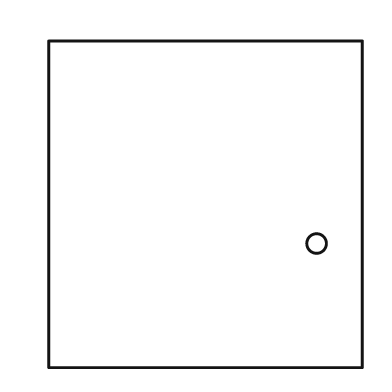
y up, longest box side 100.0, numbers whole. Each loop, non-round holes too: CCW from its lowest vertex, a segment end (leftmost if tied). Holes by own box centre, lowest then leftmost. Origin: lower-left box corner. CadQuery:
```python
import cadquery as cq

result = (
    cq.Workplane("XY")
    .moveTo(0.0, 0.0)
    .lineTo(96.0, 0.0)
    .lineTo(96.0, 100.0)
    .lineTo(0.0, 100.0)
    .close()
    .moveTo(82.0, 38.0)
    .circle(3.0)
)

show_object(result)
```